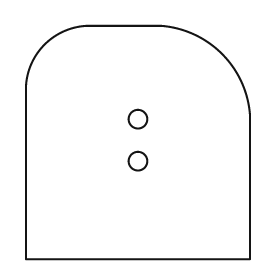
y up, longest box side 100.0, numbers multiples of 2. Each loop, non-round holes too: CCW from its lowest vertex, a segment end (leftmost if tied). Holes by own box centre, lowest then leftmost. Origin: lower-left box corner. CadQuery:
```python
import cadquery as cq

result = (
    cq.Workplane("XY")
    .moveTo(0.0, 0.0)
    .lineTo(96.0, 0.0)
    .lineTo(96.0, 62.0)
    .threePointArc((84.0, 88.0), (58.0, 100.0))
    .lineTo(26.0, 100.0)
    .threePointArc((8.0, 92.0), (0.0, 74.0))
    .close()
    .moveTo(48.0, 42.0)
    .circle(4.0)
    .moveTo(48.0, 60.0)
    .circle(4.0)
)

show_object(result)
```